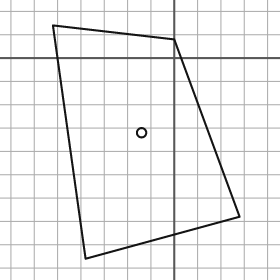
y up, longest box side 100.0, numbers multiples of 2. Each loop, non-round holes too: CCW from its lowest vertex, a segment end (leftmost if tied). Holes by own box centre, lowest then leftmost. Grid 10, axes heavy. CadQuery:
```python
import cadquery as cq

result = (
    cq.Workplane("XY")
    .moveTo(-38.0, -86.0)
    .lineTo(28.0, -68.0)
    .lineTo(0.0, 8.0)
    .lineTo(-52.0, 14.0)
    .close()
    .moveTo(-14.0, -32.0)
    .circle(2.0)
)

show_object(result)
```